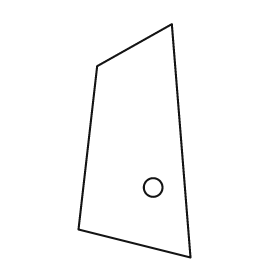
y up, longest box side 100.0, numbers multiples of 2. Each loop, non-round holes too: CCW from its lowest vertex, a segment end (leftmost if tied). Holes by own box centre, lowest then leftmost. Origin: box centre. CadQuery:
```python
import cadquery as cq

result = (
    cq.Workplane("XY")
    .moveTo(24.0, -50.0)
    .lineTo(16.0, 50.0)
    .lineTo(-16.0, 32.0)
    .lineTo(-24.0, -38.0)
    .close()
    .moveTo(8.0, -20.0)
    .circle(4.0)
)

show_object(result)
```